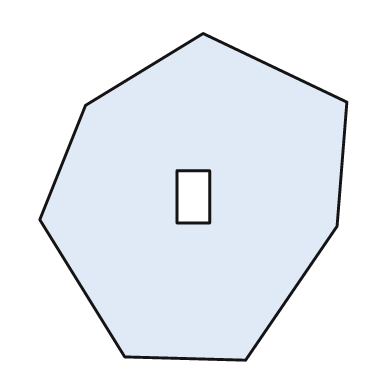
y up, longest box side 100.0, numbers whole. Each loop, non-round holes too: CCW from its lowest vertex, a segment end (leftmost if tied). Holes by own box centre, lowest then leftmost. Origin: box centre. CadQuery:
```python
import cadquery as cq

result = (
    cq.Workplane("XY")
    .moveTo(16.0, -50.0)
    .lineTo(44.0, -9.0)
    .lineTo(47.0, 29.0)
    .lineTo(3.0, 50.0)
    .lineTo(-33.0, 28.0)
    .lineTo(-47.0, -7.0)
    .lineTo(-21.0, -49.0)
    .close()
    .moveTo(-5.0, -8.0)
    .lineTo(5.0, -8.0)
    .lineTo(5.0, 8.0)
    .lineTo(-5.0, 8.0)
    .close()
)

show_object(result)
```